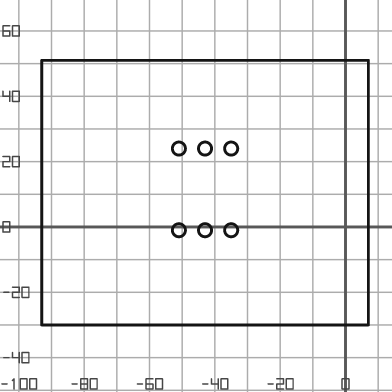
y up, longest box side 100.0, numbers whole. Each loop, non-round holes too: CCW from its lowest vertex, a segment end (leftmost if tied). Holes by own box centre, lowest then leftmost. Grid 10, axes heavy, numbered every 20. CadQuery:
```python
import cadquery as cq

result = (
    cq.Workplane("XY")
    .moveTo(-93.0, -30.0)
    .lineTo(7.0, -30.0)
    .lineTo(7.0, 51.0)
    .lineTo(-93.0, 51.0)
    .close()
    .moveTo(-51.0, -1.0)
    .circle(2.0)
    .moveTo(-43.0, -1.0)
    .circle(2.0)
    .moveTo(-35.0, -1.0)
    .circle(2.0)
    .moveTo(-51.0, 24.0)
    .circle(2.0)
    .moveTo(-43.0, 24.0)
    .circle(2.0)
    .moveTo(-35.0, 24.0)
    .circle(2.0)
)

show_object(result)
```